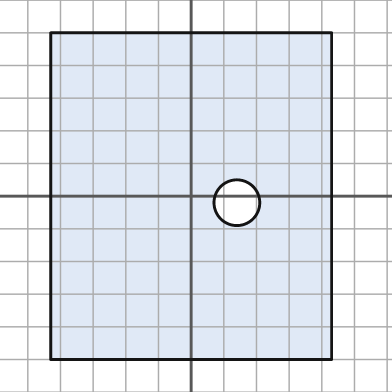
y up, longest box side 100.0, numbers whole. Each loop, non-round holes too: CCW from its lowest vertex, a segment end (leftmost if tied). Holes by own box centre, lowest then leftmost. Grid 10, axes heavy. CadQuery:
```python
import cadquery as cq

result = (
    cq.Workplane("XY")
    .moveTo(-43.0, -50.0)
    .lineTo(43.0, -50.0)
    .lineTo(43.0, 50.0)
    .lineTo(-43.0, 50.0)
    .close()
    .moveTo(14.0, -2.0)
    .circle(7.0)
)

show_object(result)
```